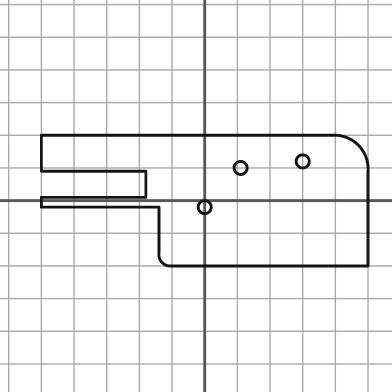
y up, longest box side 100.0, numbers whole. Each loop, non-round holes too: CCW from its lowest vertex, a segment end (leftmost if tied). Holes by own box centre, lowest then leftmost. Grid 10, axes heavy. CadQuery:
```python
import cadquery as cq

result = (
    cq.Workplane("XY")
    .moveTo(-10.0, -20.0)
    .lineTo(50.0, -20.0)
    .lineTo(50.0, 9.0)
    .threePointArc((47.0, 17.0), (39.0, 20.0))
    .lineTo(-50.0, 20.0)
    .lineTo(-50.0, 9.0)
    .lineTo(-18.0, 9.0)
    .lineTo(-18.0, 1.0)
    .lineTo(-50.0, 1.0)
    .lineTo(-50.0, -2.0)
    .lineTo(-14.0, -2.0)
    .lineTo(-14.0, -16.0)
    .threePointArc((-13.0, -19.0), (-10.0, -20.0))
    .close()
    .moveTo(0.0, -2.0)
    .circle(2.0)
    .moveTo(11.0, 10.0)
    .circle(2.0)
    .moveTo(30.0, 12.0)
    .circle(2.0)
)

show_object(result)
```